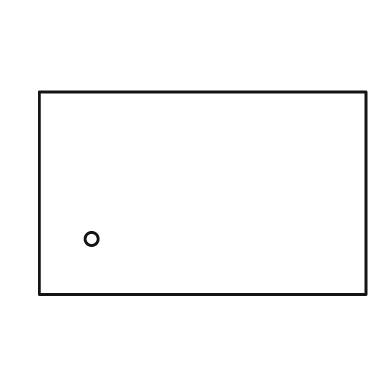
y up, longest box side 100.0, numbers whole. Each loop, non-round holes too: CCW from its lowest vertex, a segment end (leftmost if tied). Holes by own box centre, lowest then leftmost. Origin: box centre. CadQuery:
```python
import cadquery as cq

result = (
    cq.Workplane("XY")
    .moveTo(-50.0, -31.0)
    .lineTo(50.0, -31.0)
    .lineTo(50.0, 31.0)
    .lineTo(-50.0, 31.0)
    .close()
    .moveTo(-34.0, -14.0)
    .circle(2.0)
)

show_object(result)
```